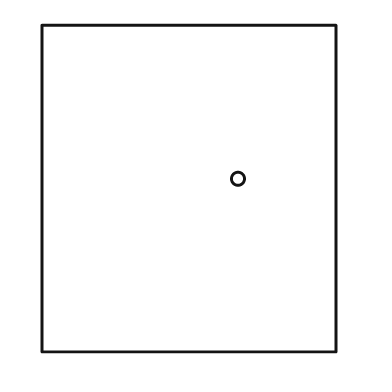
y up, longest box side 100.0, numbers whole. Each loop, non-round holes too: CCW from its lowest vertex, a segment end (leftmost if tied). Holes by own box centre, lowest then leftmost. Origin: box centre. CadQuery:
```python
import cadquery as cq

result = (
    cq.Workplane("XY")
    .moveTo(-45.0, -50.0)
    .lineTo(45.0, -50.0)
    .lineTo(45.0, 50.0)
    .lineTo(-45.0, 50.0)
    .close()
    .moveTo(15.0, 3.0)
    .circle(2.0)
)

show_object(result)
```